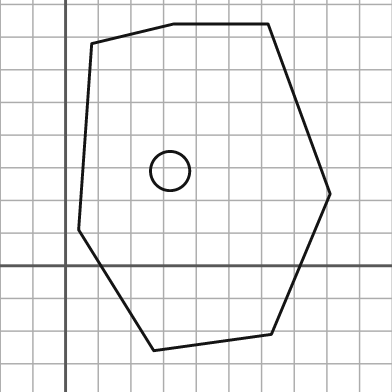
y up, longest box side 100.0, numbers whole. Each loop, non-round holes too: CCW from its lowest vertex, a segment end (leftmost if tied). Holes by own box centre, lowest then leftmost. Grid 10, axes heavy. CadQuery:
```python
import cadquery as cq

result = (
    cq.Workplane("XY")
    .moveTo(27.0, -26.0)
    .lineTo(63.0, -21.0)
    .lineTo(81.0, 22.0)
    .lineTo(62.0, 74.0)
    .lineTo(33.0, 74.0)
    .lineTo(8.0, 68.0)
    .lineTo(4.0, 11.0)
    .close()
    .moveTo(32.0, 29.0)
    .circle(6.0)
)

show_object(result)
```